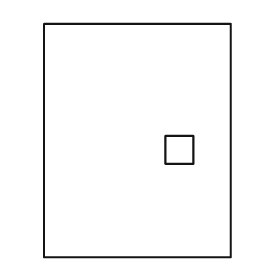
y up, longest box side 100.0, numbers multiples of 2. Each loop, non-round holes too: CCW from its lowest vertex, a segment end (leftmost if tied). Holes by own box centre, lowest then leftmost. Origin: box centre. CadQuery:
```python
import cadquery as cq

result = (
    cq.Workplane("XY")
    .moveTo(-40.0, -50.0)
    .lineTo(40.0, -50.0)
    .lineTo(40.0, 50.0)
    .lineTo(-40.0, 50.0)
    .close()
    .moveTo(12.0, -10.0)
    .lineTo(24.0, -10.0)
    .lineTo(24.0, 2.0)
    .lineTo(12.0, 2.0)
    .close()
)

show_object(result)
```